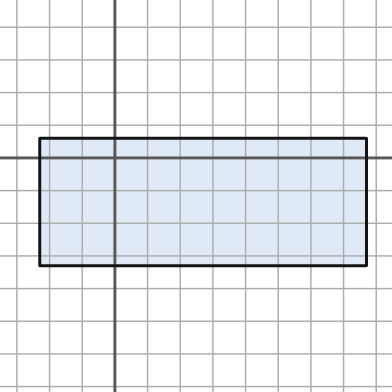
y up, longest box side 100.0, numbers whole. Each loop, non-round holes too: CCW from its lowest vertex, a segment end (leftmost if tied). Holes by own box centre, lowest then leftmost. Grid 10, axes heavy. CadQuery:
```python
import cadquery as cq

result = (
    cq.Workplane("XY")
    .moveTo(-23.0, -33.0)
    .lineTo(77.0, -33.0)
    .lineTo(77.0, 6.0)
    .lineTo(-23.0, 6.0)
    .close()
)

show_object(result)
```